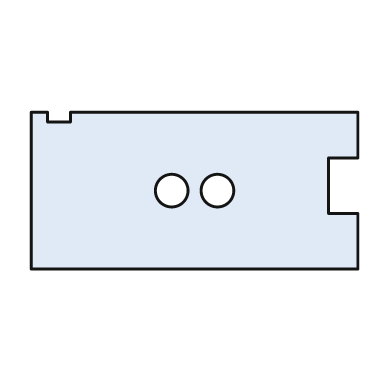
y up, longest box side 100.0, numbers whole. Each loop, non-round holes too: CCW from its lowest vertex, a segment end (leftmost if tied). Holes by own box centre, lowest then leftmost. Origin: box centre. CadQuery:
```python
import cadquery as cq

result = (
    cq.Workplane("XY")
    .moveTo(-50.0, -24.0)
    .lineTo(50.0, -24.0)
    .lineTo(50.0, -7.0)
    .lineTo(41.0, -7.0)
    .lineTo(41.0, 10.0)
    .lineTo(50.0, 10.0)
    .lineTo(50.0, 24.0)
    .lineTo(-38.0, 24.0)
    .lineTo(-38.0, 21.0)
    .lineTo(-45.0, 21.0)
    .lineTo(-45.0, 24.0)
    .lineTo(-50.0, 24.0)
    .close()
    .moveTo(-7.0, 0.0)
    .circle(5.0)
    .moveTo(7.0, 0.0)
    .circle(5.0)
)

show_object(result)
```